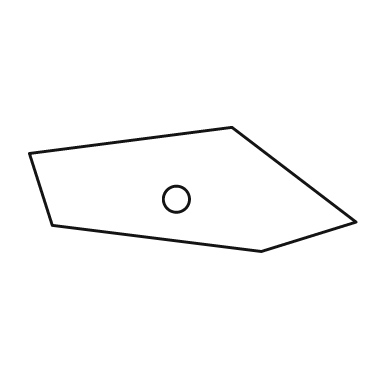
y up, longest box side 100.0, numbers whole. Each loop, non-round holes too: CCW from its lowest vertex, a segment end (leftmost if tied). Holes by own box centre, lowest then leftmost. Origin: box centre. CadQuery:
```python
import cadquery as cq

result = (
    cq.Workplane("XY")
    .moveTo(21.0, -19.0)
    .lineTo(50.0, -10.0)
    .lineTo(12.0, 19.0)
    .lineTo(-50.0, 11.0)
    .lineTo(-43.0, -11.0)
    .close()
    .moveTo(-5.0, -3.0)
    .circle(4.0)
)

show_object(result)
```